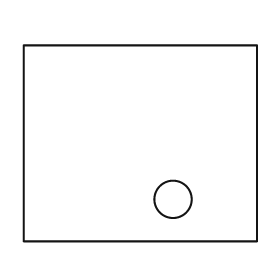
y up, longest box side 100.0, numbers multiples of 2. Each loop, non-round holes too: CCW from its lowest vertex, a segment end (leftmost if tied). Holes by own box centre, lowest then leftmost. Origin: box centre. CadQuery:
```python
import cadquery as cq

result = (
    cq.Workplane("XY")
    .moveTo(-50.0, -42.0)
    .lineTo(50.0, -42.0)
    .lineTo(50.0, 42.0)
    .lineTo(-50.0, 42.0)
    .close()
    .moveTo(14.0, -24.0)
    .circle(8.0)
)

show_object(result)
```